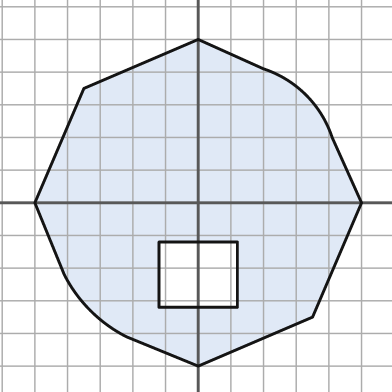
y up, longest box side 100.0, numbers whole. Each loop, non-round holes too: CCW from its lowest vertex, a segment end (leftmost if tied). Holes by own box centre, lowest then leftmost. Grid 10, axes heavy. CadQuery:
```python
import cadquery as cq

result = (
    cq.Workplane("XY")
    .moveTo(0.0, -50.0)
    .lineTo(35.0, -35.0)
    .lineTo(50.0, 0.0)
    .lineTo(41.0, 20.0)
    .threePointArc((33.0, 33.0), (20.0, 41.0))
    .lineTo(0.0, 50.0)
    .lineTo(-35.0, 35.0)
    .lineTo(-50.0, 0.0)
    .lineTo(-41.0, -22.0)
    .threePointArc((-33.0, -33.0), (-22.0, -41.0))
    .close()
    .moveTo(-12.0, -32.0)
    .lineTo(12.0, -32.0)
    .lineTo(12.0, -12.0)
    .lineTo(-12.0, -12.0)
    .close()
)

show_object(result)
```